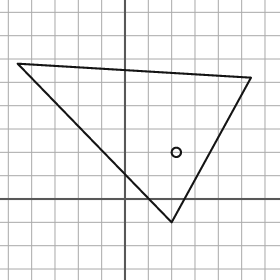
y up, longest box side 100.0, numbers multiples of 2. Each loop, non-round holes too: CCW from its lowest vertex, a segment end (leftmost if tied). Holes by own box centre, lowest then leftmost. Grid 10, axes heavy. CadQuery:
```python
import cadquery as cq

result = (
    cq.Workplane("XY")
    .moveTo(20.0, -10.0)
    .lineTo(54.0, 52.0)
    .lineTo(-46.0, 58.0)
    .close()
    .moveTo(22.0, 20.0)
    .circle(2.0)
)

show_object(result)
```